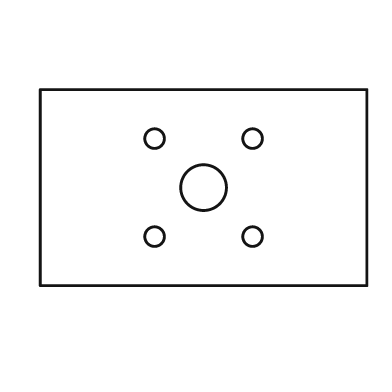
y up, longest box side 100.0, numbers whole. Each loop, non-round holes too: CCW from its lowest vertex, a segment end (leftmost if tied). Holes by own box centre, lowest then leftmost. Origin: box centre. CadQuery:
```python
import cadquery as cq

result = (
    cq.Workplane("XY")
    .moveTo(-50.0, -30.0)
    .lineTo(50.0, -30.0)
    .lineTo(50.0, 30.0)
    .lineTo(-50.0, 30.0)
    .close()
    .moveTo(-15.0, -15.0)
    .circle(3.0)
    .moveTo(15.0, -15.0)
    .circle(3.0)
    .moveTo(0.0, 0.0)
    .circle(7.0)
    .moveTo(-15.0, 15.0)
    .circle(3.0)
    .moveTo(15.0, 15.0)
    .circle(3.0)
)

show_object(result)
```